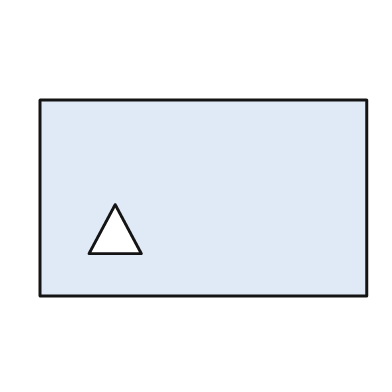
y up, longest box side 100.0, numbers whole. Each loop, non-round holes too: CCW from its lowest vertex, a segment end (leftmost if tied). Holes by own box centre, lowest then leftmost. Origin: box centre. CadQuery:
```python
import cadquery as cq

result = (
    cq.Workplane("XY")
    .moveTo(-50.0, -30.0)
    .lineTo(50.0, -30.0)
    .lineTo(50.0, 30.0)
    .lineTo(-50.0, 30.0)
    .close()
    .moveTo(-35.0, -17.0)
    .lineTo(-19.0, -17.0)
    .lineTo(-27.0, -2.0)
    .close()
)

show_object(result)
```